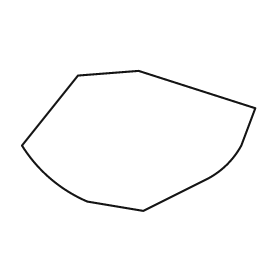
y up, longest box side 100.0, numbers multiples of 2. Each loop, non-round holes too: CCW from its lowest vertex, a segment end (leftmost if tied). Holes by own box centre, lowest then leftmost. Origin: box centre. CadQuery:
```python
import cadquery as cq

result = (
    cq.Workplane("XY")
    .moveTo(2.0, -30.0)
    .lineTo(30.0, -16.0)
    .threePointArc((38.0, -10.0), (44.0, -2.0))
    .lineTo(50.0, 14.0)
    .lineTo(0.0, 30.0)
    .lineTo(-26.0, 28.0)
    .lineTo(-50.0, -2.0)
    .threePointArc((-38.0, -16.0), (-22.0, -26.0))
    .close()
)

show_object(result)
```